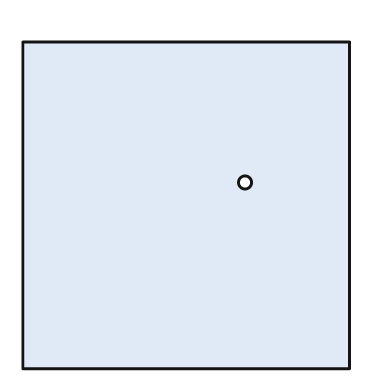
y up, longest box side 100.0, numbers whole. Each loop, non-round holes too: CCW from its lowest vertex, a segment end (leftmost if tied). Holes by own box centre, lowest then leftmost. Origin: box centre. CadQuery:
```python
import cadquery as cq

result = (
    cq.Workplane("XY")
    .moveTo(-50.0, -50.0)
    .lineTo(50.0, -50.0)
    .lineTo(50.0, 50.0)
    .lineTo(-50.0, 50.0)
    .close()
    .moveTo(18.0, 7.0)
    .circle(2.0)
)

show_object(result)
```